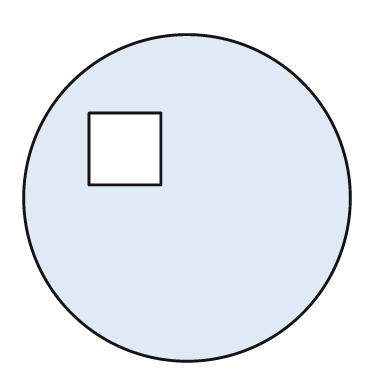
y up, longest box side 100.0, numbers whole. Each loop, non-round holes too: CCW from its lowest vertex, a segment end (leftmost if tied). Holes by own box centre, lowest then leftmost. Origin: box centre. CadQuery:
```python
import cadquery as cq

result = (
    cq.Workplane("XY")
    .moveTo(0.0, 0.0)
    .circle(50.0)
    .moveTo(-30.0, 4.0)
    .lineTo(-8.0, 4.0)
    .lineTo(-8.0, 26.0)
    .lineTo(-30.0, 26.0)
    .close()
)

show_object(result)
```